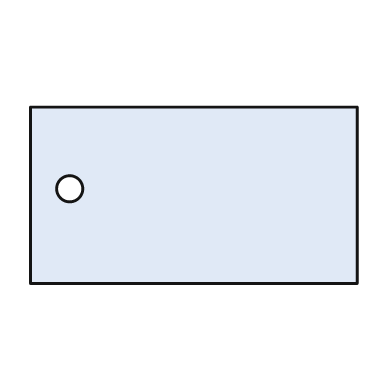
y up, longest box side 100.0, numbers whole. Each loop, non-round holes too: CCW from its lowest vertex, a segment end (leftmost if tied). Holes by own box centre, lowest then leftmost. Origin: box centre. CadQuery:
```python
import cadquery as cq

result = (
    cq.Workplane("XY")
    .moveTo(-50.0, -27.0)
    .lineTo(50.0, -27.0)
    .lineTo(50.0, 27.0)
    .lineTo(-50.0, 27.0)
    .close()
    .moveTo(-38.0, 2.0)
    .circle(4.0)
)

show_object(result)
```